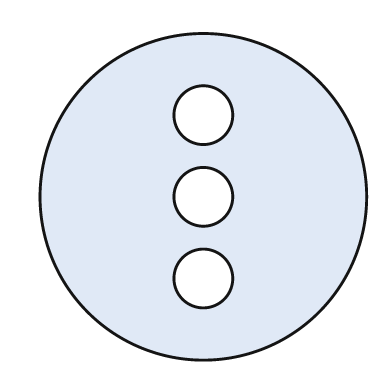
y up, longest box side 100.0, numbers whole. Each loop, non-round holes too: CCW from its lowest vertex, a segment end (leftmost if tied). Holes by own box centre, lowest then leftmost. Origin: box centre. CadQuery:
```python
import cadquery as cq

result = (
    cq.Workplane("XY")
    .moveTo(0.0, 0.0)
    .circle(50.0)
    .moveTo(0.0, -25.0)
    .circle(9.0)
    .moveTo(0.0, 0.0)
    .circle(9.0)
    .moveTo(0.0, 25.0)
    .circle(9.0)
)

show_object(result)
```